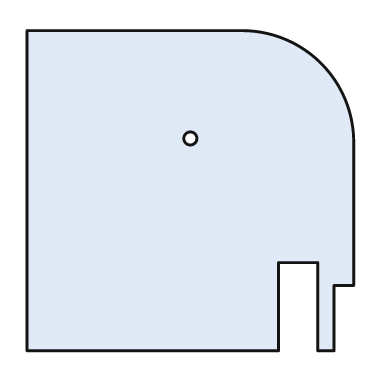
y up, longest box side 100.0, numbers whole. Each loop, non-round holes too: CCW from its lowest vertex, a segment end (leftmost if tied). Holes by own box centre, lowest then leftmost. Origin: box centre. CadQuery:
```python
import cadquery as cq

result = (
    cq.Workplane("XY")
    .moveTo(-50.0, -49.0)
    .lineTo(27.0, -49.0)
    .lineTo(27.0, -22.0)
    .lineTo(39.0, -22.0)
    .lineTo(39.0, -49.0)
    .lineTo(44.0, -49.0)
    .lineTo(44.0, -29.0)
    .lineTo(50.0, -29.0)
    .lineTo(50.0, 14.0)
    .threePointArc((40.0, 39.0), (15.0, 49.0))
    .lineTo(-50.0, 49.0)
    .close()
    .moveTo(0.0, 16.0)
    .circle(2.0)
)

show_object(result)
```